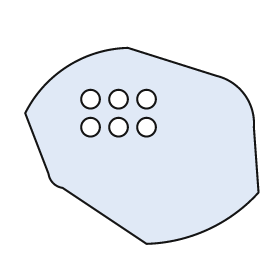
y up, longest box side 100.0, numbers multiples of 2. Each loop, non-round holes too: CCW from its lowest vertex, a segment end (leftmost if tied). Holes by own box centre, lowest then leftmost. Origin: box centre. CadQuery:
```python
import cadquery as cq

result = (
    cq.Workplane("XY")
    .moveTo(2.0, -42.0)
    .threePointArc((28.0, -36.0), (50.0, -20.0))
    .lineTo(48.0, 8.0)
    .threePointArc((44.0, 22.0), (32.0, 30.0))
    .lineTo(-6.0, 42.0)
    .threePointArc((-32.0, 34.0), (-50.0, 14.0))
    .lineTo(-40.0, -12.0)
    .threePointArc((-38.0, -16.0), (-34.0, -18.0))
    .close()
    .moveTo(-22.0, 8.0)
    .circle(4.0)
    .moveTo(-10.0, 8.0)
    .circle(4.0)
    .moveTo(2.0, 8.0)
    .circle(4.0)
    .moveTo(-22.0, 20.0)
    .circle(4.0)
    .moveTo(-10.0, 20.0)
    .circle(4.0)
    .moveTo(2.0, 20.0)
    .circle(4.0)
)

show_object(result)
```